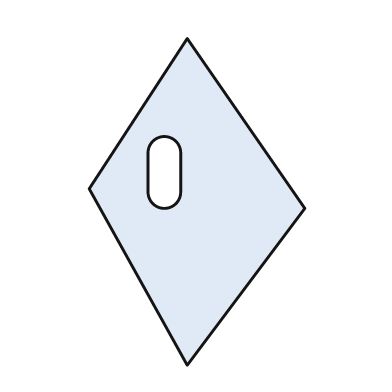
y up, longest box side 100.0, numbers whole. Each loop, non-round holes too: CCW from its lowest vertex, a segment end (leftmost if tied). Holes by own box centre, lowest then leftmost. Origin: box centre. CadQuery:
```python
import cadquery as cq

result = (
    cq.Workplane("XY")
    .moveTo(-3.0, -50.0)
    .lineTo(33.0, -2.0)
    .lineTo(-3.0, 50.0)
    .lineTo(-33.0, 4.0)
    .close()
    .moveTo(-15.0, 3.0)
    .threePointArc((-10.0, -2.0), (-5.0, 3.0))
    .lineTo(-5.0, 15.0)
    .threePointArc((-10.0, 20.0), (-15.0, 15.0))
    .close()
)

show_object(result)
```